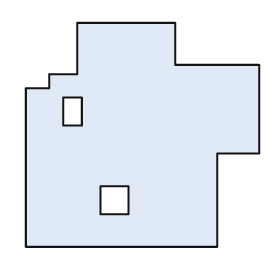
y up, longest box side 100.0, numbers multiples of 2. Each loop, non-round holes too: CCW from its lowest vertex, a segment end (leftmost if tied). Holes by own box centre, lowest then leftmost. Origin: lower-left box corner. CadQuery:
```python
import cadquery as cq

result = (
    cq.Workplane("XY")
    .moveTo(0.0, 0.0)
    .lineTo(82.0, 0.0)
    .lineTo(82.0, 40.0)
    .lineTo(100.0, 40.0)
    .lineTo(100.0, 78.0)
    .lineTo(64.0, 78.0)
    .lineTo(64.0, 96.0)
    .lineTo(22.0, 96.0)
    .lineTo(22.0, 74.0)
    .lineTo(10.0, 74.0)
    .lineTo(10.0, 68.0)
    .lineTo(0.0, 68.0)
    .close()
    .moveTo(32.0, 14.0)
    .lineTo(44.0, 14.0)
    .lineTo(44.0, 26.0)
    .lineTo(32.0, 26.0)
    .close()
    .moveTo(16.0, 52.0)
    .lineTo(24.0, 52.0)
    .lineTo(24.0, 64.0)
    .lineTo(16.0, 64.0)
    .close()
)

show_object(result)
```